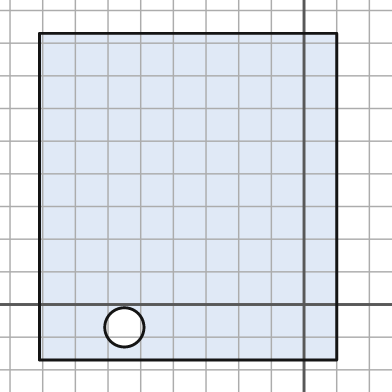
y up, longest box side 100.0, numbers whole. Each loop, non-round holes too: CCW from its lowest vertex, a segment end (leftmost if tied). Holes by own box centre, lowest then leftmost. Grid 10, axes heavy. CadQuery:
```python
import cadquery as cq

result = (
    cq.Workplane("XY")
    .moveTo(-81.0, -17.0)
    .lineTo(10.0, -17.0)
    .lineTo(10.0, 83.0)
    .lineTo(-81.0, 83.0)
    .close()
    .moveTo(-55.0, -7.0)
    .circle(6.0)
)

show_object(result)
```